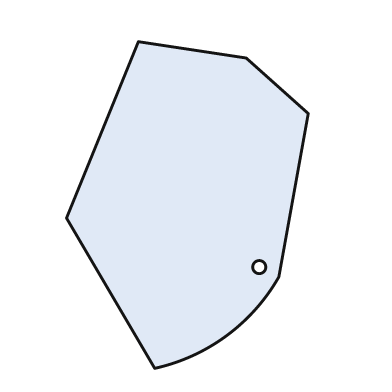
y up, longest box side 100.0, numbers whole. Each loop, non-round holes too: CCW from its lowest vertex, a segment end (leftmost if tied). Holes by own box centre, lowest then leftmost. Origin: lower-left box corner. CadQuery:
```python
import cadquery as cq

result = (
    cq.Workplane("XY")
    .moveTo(27.0, 0.0)
    .threePointArc((49.0, 10.0), (65.0, 28.0))
    .lineTo(74.0, 78.0)
    .lineTo(55.0, 95.0)
    .lineTo(22.0, 100.0)
    .lineTo(0.0, 46.0)
    .close()
    .moveTo(59.0, 31.0)
    .circle(2.0)
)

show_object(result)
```